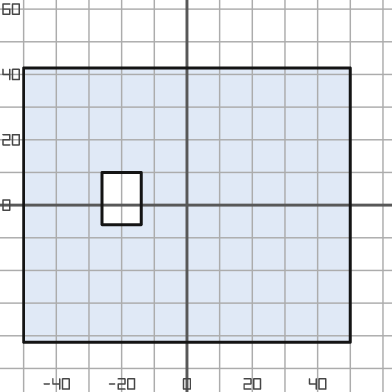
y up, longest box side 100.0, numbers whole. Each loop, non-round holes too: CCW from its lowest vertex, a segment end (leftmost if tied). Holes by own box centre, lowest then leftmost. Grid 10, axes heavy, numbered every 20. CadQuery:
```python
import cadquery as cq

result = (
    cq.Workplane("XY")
    .moveTo(-50.0, -42.0)
    .lineTo(50.0, -42.0)
    .lineTo(50.0, 42.0)
    .lineTo(-50.0, 42.0)
    .close()
    .moveTo(-26.0, -6.0)
    .lineTo(-14.0, -6.0)
    .lineTo(-14.0, 10.0)
    .lineTo(-26.0, 10.0)
    .close()
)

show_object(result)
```